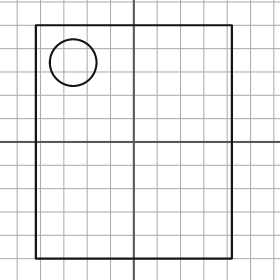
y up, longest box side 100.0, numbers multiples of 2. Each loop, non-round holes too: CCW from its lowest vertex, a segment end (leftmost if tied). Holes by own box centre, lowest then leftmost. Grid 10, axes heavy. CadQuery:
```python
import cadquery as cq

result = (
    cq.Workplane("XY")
    .moveTo(-42.0, -50.0)
    .lineTo(42.0, -50.0)
    .lineTo(42.0, 50.0)
    .lineTo(-42.0, 50.0)
    .close()
    .moveTo(-26.0, 34.0)
    .circle(10.0)
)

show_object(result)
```